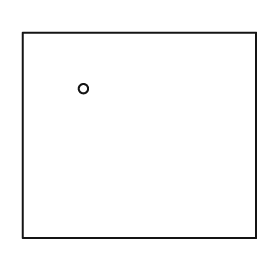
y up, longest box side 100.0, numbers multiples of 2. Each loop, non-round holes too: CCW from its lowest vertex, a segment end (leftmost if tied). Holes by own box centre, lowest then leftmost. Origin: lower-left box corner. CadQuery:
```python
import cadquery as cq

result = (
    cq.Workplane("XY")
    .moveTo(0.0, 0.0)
    .lineTo(100.0, 0.0)
    .lineTo(100.0, 88.0)
    .lineTo(0.0, 88.0)
    .close()
    .moveTo(26.0, 64.0)
    .circle(2.0)
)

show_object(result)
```